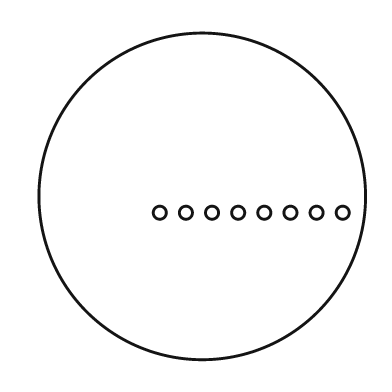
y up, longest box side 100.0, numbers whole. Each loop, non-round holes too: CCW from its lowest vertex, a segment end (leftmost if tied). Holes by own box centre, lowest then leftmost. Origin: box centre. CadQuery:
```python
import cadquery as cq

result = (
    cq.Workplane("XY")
    .moveTo(0.0, 0.0)
    .circle(50.0)
    .moveTo(-13.0, -5.0)
    .circle(2.0)
    .moveTo(-5.0, -5.0)
    .circle(2.0)
    .moveTo(3.0, -5.0)
    .circle(2.0)
    .moveTo(11.0, -5.0)
    .circle(2.0)
    .moveTo(19.0, -5.0)
    .circle(2.0)
    .moveTo(27.0, -5.0)
    .circle(2.0)
    .moveTo(35.0, -5.0)
    .circle(2.0)
    .moveTo(43.0, -5.0)
    .circle(2.0)
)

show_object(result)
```